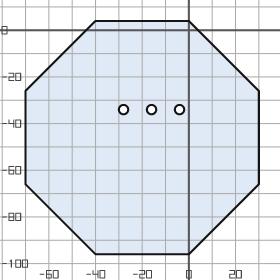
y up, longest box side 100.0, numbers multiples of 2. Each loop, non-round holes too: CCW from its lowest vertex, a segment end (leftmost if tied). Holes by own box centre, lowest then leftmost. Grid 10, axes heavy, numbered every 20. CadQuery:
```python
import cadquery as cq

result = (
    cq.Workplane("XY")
    .moveTo(-40.0, -96.0)
    .lineTo(0.0, -96.0)
    .lineTo(30.0, -66.0)
    .lineTo(30.0, -26.0)
    .lineTo(0.0, 4.0)
    .lineTo(-40.0, 4.0)
    .lineTo(-70.0, -26.0)
    .lineTo(-70.0, -66.0)
    .close()
    .moveTo(-28.0, -34.0)
    .circle(2.0)
    .moveTo(-16.0, -34.0)
    .circle(2.0)
    .moveTo(-4.0, -34.0)
    .circle(2.0)
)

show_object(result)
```